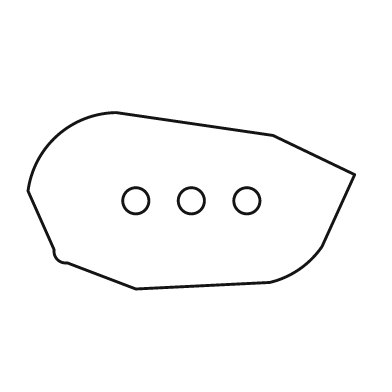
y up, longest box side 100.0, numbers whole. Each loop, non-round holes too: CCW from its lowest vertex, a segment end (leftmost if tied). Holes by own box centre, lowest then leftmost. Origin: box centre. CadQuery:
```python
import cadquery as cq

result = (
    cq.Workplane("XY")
    .moveTo(-17.0, -27.0)
    .lineTo(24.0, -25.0)
    .threePointArc((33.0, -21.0), (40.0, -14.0))
    .lineTo(50.0, 8.0)
    .lineTo(25.0, 20.0)
    .lineTo(-23.0, 27.0)
    .threePointArc((-41.0, 20.0), (-50.0, 3.0))
    .lineTo(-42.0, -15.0)
    .threePointArc((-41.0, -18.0), (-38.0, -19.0))
    .close()
    .moveTo(-17.0, 0.0)
    .circle(4.0)
    .moveTo(0.0, 0.0)
    .circle(4.0)
    .moveTo(17.0, 0.0)
    .circle(4.0)
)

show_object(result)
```